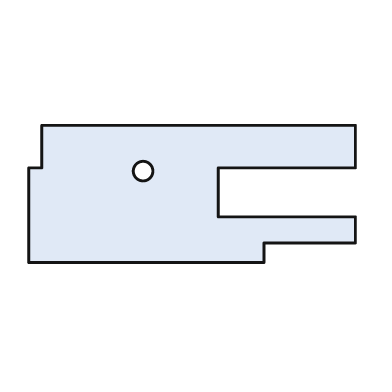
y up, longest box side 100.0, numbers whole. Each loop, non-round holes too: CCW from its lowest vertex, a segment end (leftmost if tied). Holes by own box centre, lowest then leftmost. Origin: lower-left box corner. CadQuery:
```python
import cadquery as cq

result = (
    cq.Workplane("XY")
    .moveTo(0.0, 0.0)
    .lineTo(72.0, 0.0)
    .lineTo(72.0, 6.0)
    .lineTo(100.0, 6.0)
    .lineTo(100.0, 14.0)
    .lineTo(58.0, 14.0)
    .lineTo(58.0, 29.0)
    .lineTo(100.0, 29.0)
    .lineTo(100.0, 42.0)
    .lineTo(4.0, 42.0)
    .lineTo(4.0, 29.0)
    .lineTo(0.0, 29.0)
    .close()
    .moveTo(35.0, 28.0)
    .circle(3.0)
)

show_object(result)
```